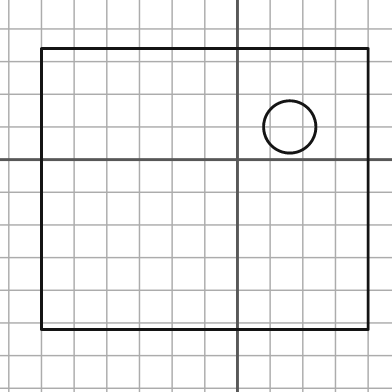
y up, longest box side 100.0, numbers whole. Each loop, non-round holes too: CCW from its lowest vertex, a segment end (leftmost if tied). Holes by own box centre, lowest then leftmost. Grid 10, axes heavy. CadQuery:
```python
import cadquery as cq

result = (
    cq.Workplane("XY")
    .moveTo(-60.0, -52.0)
    .lineTo(40.0, -52.0)
    .lineTo(40.0, 34.0)
    .lineTo(-60.0, 34.0)
    .close()
    .moveTo(16.0, 10.0)
    .circle(8.0)
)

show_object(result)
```